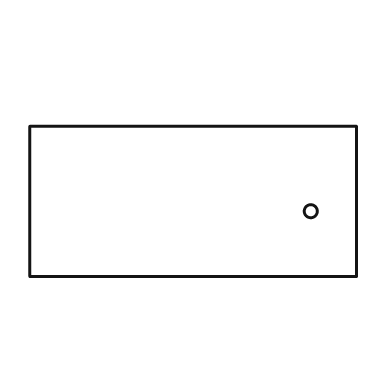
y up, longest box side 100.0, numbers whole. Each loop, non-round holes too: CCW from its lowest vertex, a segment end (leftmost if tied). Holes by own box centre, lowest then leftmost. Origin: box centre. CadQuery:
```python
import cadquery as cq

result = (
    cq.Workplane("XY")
    .moveTo(-50.0, -23.0)
    .lineTo(50.0, -23.0)
    .lineTo(50.0, 23.0)
    .lineTo(-50.0, 23.0)
    .close()
    .moveTo(36.0, -3.0)
    .circle(2.0)
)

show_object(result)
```